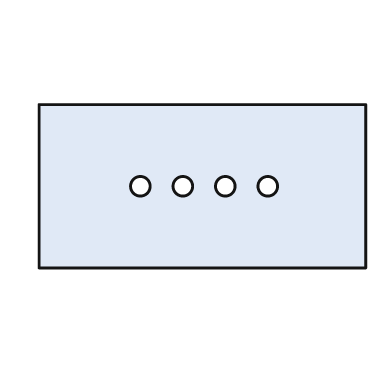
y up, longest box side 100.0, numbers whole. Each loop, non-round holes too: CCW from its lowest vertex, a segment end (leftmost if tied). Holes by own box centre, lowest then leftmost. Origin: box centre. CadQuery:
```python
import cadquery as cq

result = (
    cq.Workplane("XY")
    .moveTo(-50.0, -25.0)
    .lineTo(50.0, -25.0)
    .lineTo(50.0, 25.0)
    .lineTo(-50.0, 25.0)
    .close()
    .moveTo(-19.0, 0.0)
    .circle(3.0)
    .moveTo(-6.0, 0.0)
    .circle(3.0)
    .moveTo(7.0, 0.0)
    .circle(3.0)
    .moveTo(20.0, 0.0)
    .circle(3.0)
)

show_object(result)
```